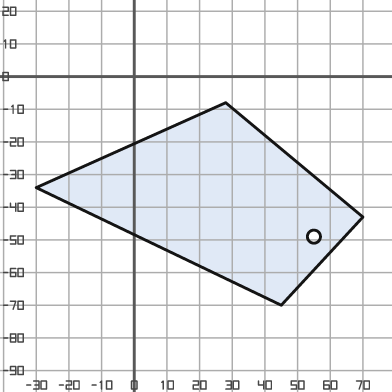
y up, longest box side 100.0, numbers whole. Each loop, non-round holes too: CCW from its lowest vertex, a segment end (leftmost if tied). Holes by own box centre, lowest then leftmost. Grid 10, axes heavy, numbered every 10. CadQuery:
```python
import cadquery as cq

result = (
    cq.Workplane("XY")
    .moveTo(45.0, -70.0)
    .lineTo(70.0, -43.0)
    .lineTo(28.0, -8.0)
    .lineTo(-30.0, -34.0)
    .close()
    .moveTo(55.0, -49.0)
    .circle(2.0)
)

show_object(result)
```